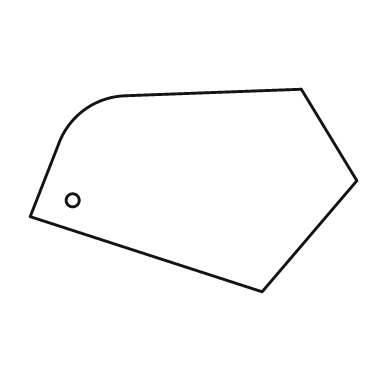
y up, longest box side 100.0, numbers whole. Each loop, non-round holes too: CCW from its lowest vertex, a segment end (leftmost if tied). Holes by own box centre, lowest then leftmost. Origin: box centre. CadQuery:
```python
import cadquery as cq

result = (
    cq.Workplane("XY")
    .moveTo(21.0, -31.0)
    .lineTo(50.0, 3.0)
    .lineTo(33.0, 31.0)
    .lineTo(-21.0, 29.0)
    .threePointArc((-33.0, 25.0), (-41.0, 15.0))
    .lineTo(-50.0, -8.0)
    .close()
    .moveTo(-37.0, -3.0)
    .circle(2.0)
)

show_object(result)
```